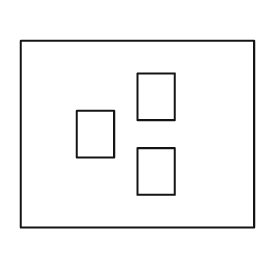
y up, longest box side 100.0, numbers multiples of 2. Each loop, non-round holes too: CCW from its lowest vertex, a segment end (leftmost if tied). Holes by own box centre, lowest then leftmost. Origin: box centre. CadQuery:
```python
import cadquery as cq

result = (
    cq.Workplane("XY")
    .moveTo(-50.0, -40.0)
    .lineTo(50.0, -40.0)
    .lineTo(50.0, 40.0)
    .lineTo(-50.0, 40.0)
    .close()
    .moveTo(0.0, -26.0)
    .lineTo(16.0, -26.0)
    .lineTo(16.0, -6.0)
    .lineTo(0.0, -6.0)
    .close()
    .moveTo(-26.0, -10.0)
    .lineTo(-10.0, -10.0)
    .lineTo(-10.0, 10.0)
    .lineTo(-26.0, 10.0)
    .close()
    .moveTo(0.0, 6.0)
    .lineTo(16.0, 6.0)
    .lineTo(16.0, 26.0)
    .lineTo(0.0, 26.0)
    .close()
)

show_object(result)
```